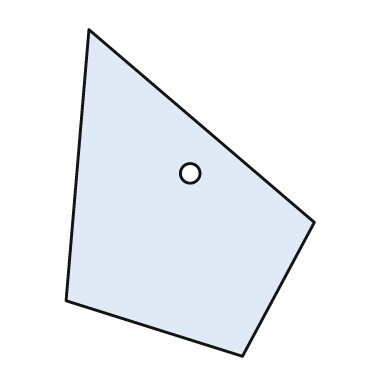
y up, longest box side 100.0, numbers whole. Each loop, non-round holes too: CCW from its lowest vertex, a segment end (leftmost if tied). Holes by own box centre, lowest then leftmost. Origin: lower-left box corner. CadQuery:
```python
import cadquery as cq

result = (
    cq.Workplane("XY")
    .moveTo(54.0, 0.0)
    .lineTo(76.0, 41.0)
    .lineTo(7.0, 100.0)
    .lineTo(0.0, 17.0)
    .close()
    .moveTo(38.0, 56.0)
    .circle(3.0)
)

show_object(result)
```